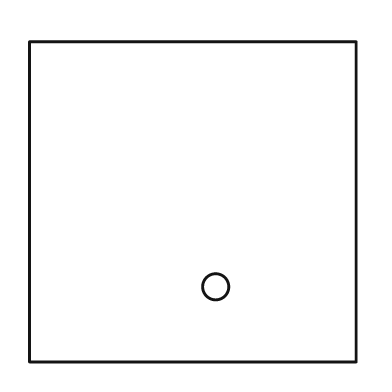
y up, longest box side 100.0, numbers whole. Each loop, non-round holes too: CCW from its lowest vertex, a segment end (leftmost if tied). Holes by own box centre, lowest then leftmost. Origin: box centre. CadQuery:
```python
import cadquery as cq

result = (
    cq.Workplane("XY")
    .moveTo(-50.0, -49.0)
    .lineTo(50.0, -49.0)
    .lineTo(50.0, 49.0)
    .lineTo(-50.0, 49.0)
    .close()
    .moveTo(7.0, -26.0)
    .circle(4.0)
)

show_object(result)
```